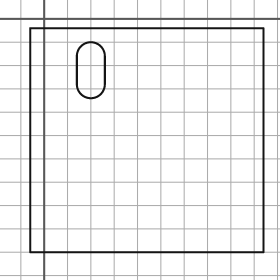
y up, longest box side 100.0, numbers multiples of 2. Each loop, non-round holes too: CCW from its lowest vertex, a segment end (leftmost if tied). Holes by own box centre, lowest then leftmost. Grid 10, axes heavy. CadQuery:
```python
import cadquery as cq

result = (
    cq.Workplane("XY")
    .moveTo(-6.0, -100.0)
    .lineTo(94.0, -100.0)
    .lineTo(94.0, -4.0)
    .lineTo(-6.0, -4.0)
    .close()
    .moveTo(14.0, -28.0)
    .threePointArc((20.0, -34.0), (26.0, -28.0))
    .lineTo(26.0, -16.0)
    .threePointArc((20.0, -10.0), (14.0, -16.0))
    .close()
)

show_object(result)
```